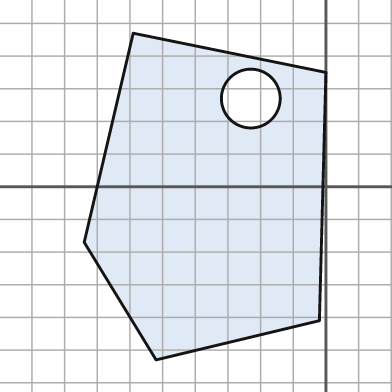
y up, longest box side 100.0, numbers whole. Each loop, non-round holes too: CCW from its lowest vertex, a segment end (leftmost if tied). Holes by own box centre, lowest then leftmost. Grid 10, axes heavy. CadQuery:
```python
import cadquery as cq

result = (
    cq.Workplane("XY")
    .moveTo(-52.0, -53.0)
    .lineTo(-2.0, -41.0)
    .lineTo(0.0, 35.0)
    .lineTo(-59.0, 47.0)
    .lineTo(-74.0, -17.0)
    .close()
    .moveTo(-23.0, 27.0)
    .circle(9.0)
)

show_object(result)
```